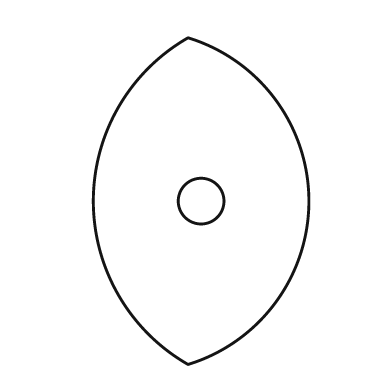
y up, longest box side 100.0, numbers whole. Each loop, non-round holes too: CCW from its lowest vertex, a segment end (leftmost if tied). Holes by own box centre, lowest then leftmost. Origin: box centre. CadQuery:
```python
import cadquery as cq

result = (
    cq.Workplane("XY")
    .moveTo(-4.0, -50.0)
    .threePointArc((33.0, 0.0), (-4.0, 50.0))
    .threePointArc((-33.0, 0.0), (-4.0, -50.0))
    .close()
    .moveTo(0.0, 0.0)
    .circle(7.0)
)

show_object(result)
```